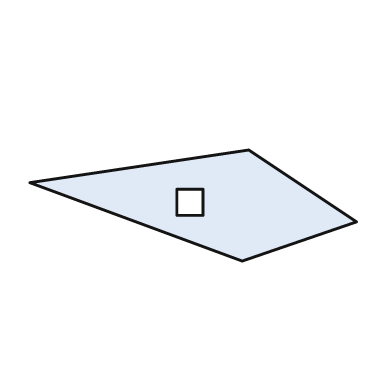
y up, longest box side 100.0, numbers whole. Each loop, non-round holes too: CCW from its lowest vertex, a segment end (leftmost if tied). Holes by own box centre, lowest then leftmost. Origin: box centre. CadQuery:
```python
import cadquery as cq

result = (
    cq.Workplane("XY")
    .moveTo(15.0, -17.0)
    .lineTo(50.0, -5.0)
    .lineTo(17.0, 17.0)
    .lineTo(-50.0, 7.0)
    .close()
    .moveTo(-5.0, -3.0)
    .lineTo(3.0, -3.0)
    .lineTo(3.0, 5.0)
    .lineTo(-5.0, 5.0)
    .close()
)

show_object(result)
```